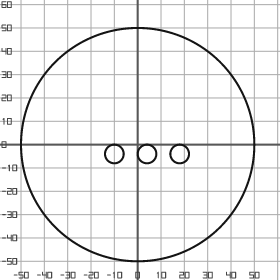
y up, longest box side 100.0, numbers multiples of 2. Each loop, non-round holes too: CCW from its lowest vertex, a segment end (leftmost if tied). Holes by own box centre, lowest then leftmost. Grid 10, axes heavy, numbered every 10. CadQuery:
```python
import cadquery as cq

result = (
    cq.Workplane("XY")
    .moveTo(0.0, 0.0)
    .circle(50.0)
    .moveTo(-10.0, -4.0)
    .circle(4.0)
    .moveTo(4.0, -4.0)
    .circle(4.0)
    .moveTo(18.0, -4.0)
    .circle(4.0)
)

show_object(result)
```